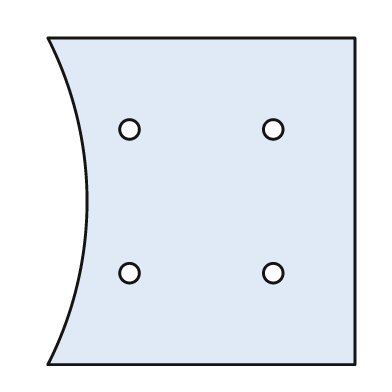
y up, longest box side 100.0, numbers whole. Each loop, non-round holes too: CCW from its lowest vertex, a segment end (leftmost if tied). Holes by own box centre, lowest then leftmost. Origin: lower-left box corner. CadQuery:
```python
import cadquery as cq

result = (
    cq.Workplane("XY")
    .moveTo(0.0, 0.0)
    .lineTo(94.0, 0.0)
    .lineTo(94.0, 100.0)
    .lineTo(0.0, 100.0)
    .threePointArc((12.0, 50.0), (0.0, 0.0))
    .close()
    .moveTo(25.0, 28.0)
    .circle(3.0)
    .moveTo(69.0, 28.0)
    .circle(3.0)
    .moveTo(25.0, 72.0)
    .circle(3.0)
    .moveTo(69.0, 72.0)
    .circle(3.0)
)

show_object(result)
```